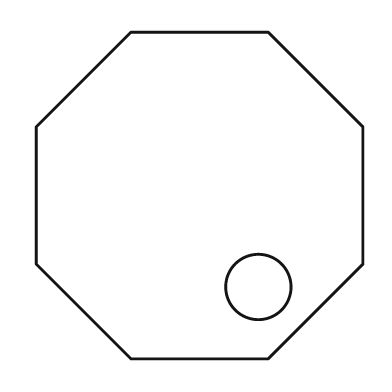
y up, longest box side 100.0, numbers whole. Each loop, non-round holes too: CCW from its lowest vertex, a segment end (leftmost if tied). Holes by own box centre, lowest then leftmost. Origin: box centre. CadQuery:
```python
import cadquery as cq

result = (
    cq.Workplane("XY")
    .moveTo(-21.0, -50.0)
    .lineTo(21.0, -50.0)
    .lineTo(50.0, -21.0)
    .lineTo(50.0, 21.0)
    .lineTo(21.0, 50.0)
    .lineTo(-21.0, 50.0)
    .lineTo(-50.0, 21.0)
    .lineTo(-50.0, -21.0)
    .close()
    .moveTo(18.0, -28.0)
    .circle(10.0)
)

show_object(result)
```